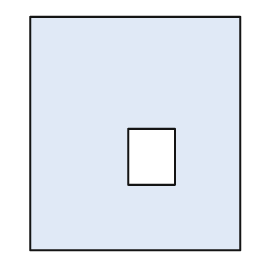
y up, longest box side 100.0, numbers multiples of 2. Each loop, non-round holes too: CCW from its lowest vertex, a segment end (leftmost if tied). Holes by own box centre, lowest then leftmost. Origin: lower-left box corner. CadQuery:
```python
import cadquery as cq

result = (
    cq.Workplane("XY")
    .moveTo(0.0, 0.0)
    .lineTo(90.0, 0.0)
    .lineTo(90.0, 100.0)
    .lineTo(0.0, 100.0)
    .close()
    .moveTo(42.0, 28.0)
    .lineTo(62.0, 28.0)
    .lineTo(62.0, 52.0)
    .lineTo(42.0, 52.0)
    .close()
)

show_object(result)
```